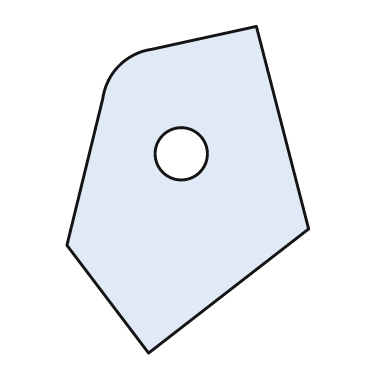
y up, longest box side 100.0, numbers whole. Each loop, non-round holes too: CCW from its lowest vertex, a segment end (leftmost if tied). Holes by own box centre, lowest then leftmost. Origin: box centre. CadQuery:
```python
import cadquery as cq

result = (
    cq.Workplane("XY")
    .moveTo(-12.0, -50.0)
    .lineTo(37.0, -12.0)
    .lineTo(21.0, 50.0)
    .lineTo(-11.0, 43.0)
    .threePointArc((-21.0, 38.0), (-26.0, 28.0))
    .lineTo(-37.0, -17.0)
    .close()
    .moveTo(-2.0, 11.0)
    .circle(8.0)
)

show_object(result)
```